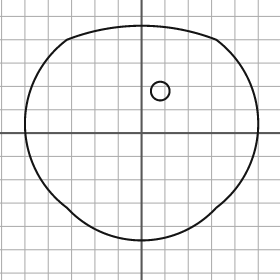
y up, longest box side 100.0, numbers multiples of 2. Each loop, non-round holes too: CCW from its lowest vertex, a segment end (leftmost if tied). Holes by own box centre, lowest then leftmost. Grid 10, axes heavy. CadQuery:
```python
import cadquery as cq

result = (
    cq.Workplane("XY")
    .moveTo(-32.0, -32.0)
    .threePointArc((0.0, -46.0), (32.0, -32.0))
    .threePointArc((50.0, 4.0), (32.0, 40.0))
    .threePointArc((0.0, 46.0), (-32.0, 40.0))
    .threePointArc((-50.0, 4.0), (-32.0, -32.0))
    .close()
    .moveTo(8.0, 18.0)
    .circle(4.0)
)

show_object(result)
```